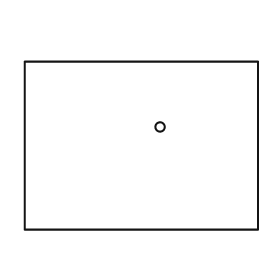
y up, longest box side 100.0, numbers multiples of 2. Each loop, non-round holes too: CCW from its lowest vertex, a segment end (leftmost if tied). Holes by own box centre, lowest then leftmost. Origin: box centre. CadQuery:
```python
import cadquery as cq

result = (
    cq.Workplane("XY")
    .moveTo(-50.0, -36.0)
    .lineTo(50.0, -36.0)
    .lineTo(50.0, 36.0)
    .lineTo(-50.0, 36.0)
    .close()
    .moveTo(8.0, 8.0)
    .circle(2.0)
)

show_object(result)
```